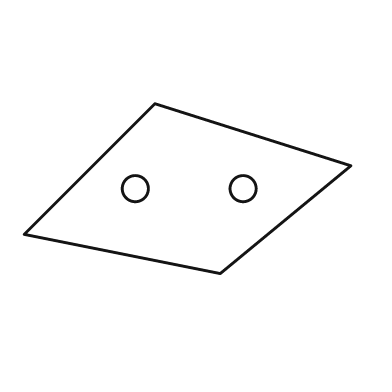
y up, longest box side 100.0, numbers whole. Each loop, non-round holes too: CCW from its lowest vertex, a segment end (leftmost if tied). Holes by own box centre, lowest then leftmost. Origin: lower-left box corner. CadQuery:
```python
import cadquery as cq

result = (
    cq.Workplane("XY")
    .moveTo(60.0, 0.0)
    .lineTo(100.0, 33.0)
    .lineTo(40.0, 52.0)
    .lineTo(0.0, 12.0)
    .close()
    .moveTo(34.0, 26.0)
    .circle(4.0)
    .moveTo(67.0, 26.0)
    .circle(4.0)
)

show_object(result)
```